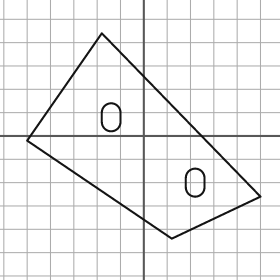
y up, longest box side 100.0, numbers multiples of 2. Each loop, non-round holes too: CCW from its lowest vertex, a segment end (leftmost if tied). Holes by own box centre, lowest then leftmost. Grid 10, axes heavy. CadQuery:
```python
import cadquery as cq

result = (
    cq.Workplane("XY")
    .moveTo(12.0, -44.0)
    .lineTo(50.0, -26.0)
    .lineTo(-18.0, 44.0)
    .lineTo(-50.0, -2.0)
    .close()
    .moveTo(18.0, -22.0)
    .threePointArc((22.0, -26.0), (26.0, -22.0))
    .lineTo(26.0, -18.0)
    .threePointArc((22.0, -14.0), (18.0, -18.0))
    .close()
    .moveTo(-18.0, 6.0)
    .threePointArc((-14.0, 2.0), (-10.0, 6.0))
    .lineTo(-10.0, 10.0)
    .threePointArc((-14.0, 14.0), (-18.0, 10.0))
    .close()
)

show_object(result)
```